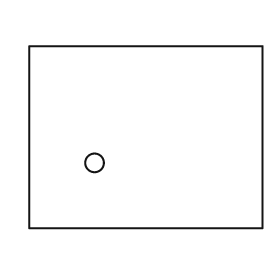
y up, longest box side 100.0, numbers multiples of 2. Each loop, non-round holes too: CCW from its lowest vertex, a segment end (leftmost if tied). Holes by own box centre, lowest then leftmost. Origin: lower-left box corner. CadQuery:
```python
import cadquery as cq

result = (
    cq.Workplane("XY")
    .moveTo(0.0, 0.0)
    .lineTo(100.0, 0.0)
    .lineTo(100.0, 78.0)
    .lineTo(0.0, 78.0)
    .close()
    .moveTo(28.0, 28.0)
    .circle(4.0)
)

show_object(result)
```